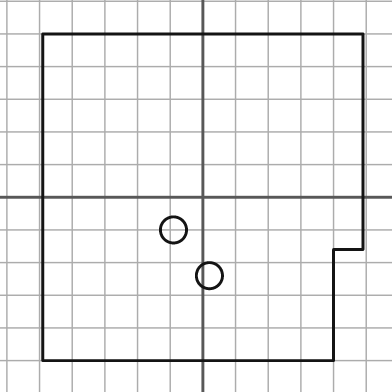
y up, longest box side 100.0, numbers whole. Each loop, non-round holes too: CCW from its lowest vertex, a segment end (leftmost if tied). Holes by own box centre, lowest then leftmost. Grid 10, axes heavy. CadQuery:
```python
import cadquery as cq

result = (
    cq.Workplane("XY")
    .moveTo(-49.0, -50.0)
    .lineTo(40.0, -50.0)
    .lineTo(40.0, -16.0)
    .lineTo(49.0, -16.0)
    .lineTo(49.0, 50.0)
    .lineTo(-49.0, 50.0)
    .close()
    .moveTo(2.0, -24.0)
    .circle(4.0)
    .moveTo(-9.0, -10.0)
    .circle(4.0)
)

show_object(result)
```